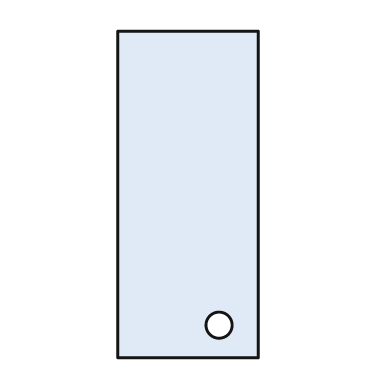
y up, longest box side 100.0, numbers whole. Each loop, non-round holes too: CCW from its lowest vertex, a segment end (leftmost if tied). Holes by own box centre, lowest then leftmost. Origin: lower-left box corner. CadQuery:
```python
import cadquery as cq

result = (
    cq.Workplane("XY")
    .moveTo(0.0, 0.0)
    .lineTo(43.0, 0.0)
    .lineTo(43.0, 100.0)
    .lineTo(0.0, 100.0)
    .close()
    .moveTo(31.0, 10.0)
    .circle(4.0)
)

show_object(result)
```